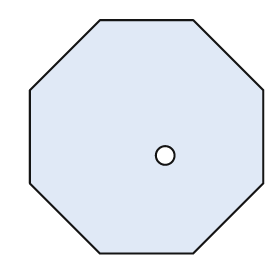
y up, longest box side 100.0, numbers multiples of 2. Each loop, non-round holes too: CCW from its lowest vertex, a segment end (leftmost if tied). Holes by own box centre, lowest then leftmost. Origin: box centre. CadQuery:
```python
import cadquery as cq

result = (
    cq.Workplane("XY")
    .moveTo(-20.0, -50.0)
    .lineTo(20.0, -50.0)
    .lineTo(50.0, -20.0)
    .lineTo(50.0, 20.0)
    .lineTo(20.0, 50.0)
    .lineTo(-20.0, 50.0)
    .lineTo(-50.0, 20.0)
    .lineTo(-50.0, -20.0)
    .close()
    .moveTo(8.0, -8.0)
    .circle(4.0)
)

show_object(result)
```